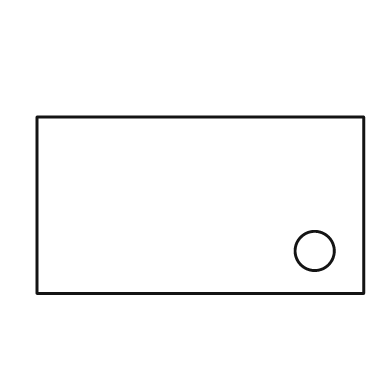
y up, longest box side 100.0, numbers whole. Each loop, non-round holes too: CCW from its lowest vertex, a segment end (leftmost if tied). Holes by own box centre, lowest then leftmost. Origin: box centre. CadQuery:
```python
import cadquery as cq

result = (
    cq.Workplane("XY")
    .moveTo(-50.0, -27.0)
    .lineTo(50.0, -27.0)
    .lineTo(50.0, 27.0)
    .lineTo(-50.0, 27.0)
    .close()
    .moveTo(35.0, -14.0)
    .circle(6.0)
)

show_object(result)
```